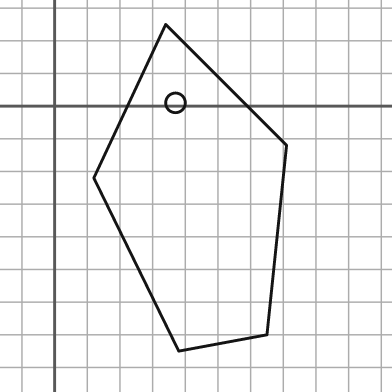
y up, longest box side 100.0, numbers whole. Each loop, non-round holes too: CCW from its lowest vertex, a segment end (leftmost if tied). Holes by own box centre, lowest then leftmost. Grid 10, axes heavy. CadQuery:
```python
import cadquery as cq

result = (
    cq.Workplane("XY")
    .moveTo(38.0, -75.0)
    .lineTo(65.0, -70.0)
    .lineTo(71.0, -12.0)
    .lineTo(34.0, 25.0)
    .lineTo(12.0, -22.0)
    .close()
    .moveTo(37.0, 1.0)
    .circle(3.0)
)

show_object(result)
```